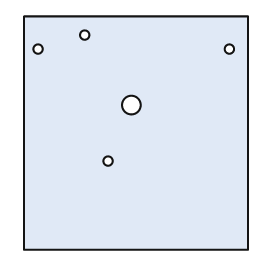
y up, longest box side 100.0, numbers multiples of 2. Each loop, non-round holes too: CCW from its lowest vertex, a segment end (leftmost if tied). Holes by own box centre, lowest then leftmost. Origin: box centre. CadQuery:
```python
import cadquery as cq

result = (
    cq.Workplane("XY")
    .moveTo(-48.0, -50.0)
    .lineTo(48.0, -50.0)
    .lineTo(48.0, 50.0)
    .lineTo(-48.0, 50.0)
    .close()
    .moveTo(-12.0, -12.0)
    .circle(2.0)
    .moveTo(-2.0, 12.0)
    .circle(4.0)
    .moveTo(-42.0, 36.0)
    .circle(2.0)
    .moveTo(40.0, 36.0)
    .circle(2.0)
    .moveTo(-22.0, 42.0)
    .circle(2.0)
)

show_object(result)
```